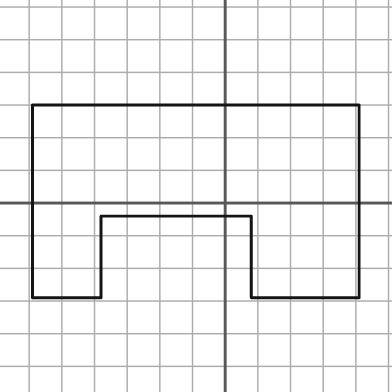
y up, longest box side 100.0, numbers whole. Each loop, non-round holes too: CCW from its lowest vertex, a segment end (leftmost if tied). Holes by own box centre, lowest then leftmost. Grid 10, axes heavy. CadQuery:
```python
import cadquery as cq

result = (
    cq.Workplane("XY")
    .moveTo(-59.0, -29.0)
    .lineTo(-38.0, -29.0)
    .lineTo(-38.0, -4.0)
    .lineTo(8.0, -4.0)
    .lineTo(8.0, -29.0)
    .lineTo(41.0, -29.0)
    .lineTo(41.0, 30.0)
    .lineTo(-59.0, 30.0)
    .close()
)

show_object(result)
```